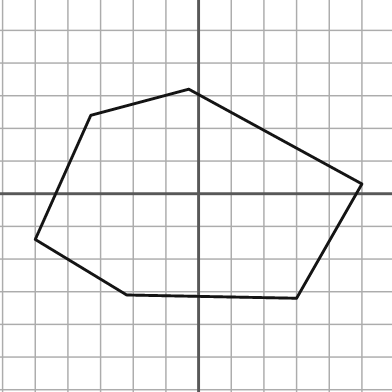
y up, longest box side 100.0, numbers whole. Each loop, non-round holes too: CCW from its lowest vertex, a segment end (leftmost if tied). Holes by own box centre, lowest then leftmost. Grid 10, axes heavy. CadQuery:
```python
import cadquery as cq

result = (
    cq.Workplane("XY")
    .moveTo(30.0, -32.0)
    .lineTo(50.0, 3.0)
    .lineTo(-3.0, 32.0)
    .lineTo(-33.0, 24.0)
    .lineTo(-50.0, -14.0)
    .lineTo(-22.0, -31.0)
    .close()
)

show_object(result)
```